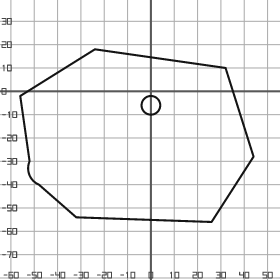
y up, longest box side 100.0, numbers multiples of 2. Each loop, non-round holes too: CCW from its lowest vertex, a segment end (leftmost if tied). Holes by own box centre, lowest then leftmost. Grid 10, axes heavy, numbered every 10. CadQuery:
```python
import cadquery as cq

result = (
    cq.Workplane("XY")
    .moveTo(26.0, -56.0)
    .lineTo(44.0, -28.0)
    .lineTo(32.0, 10.0)
    .lineTo(-24.0, 18.0)
    .lineTo(-56.0, -2.0)
    .lineTo(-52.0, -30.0)
    .threePointArc((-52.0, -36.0), (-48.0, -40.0))
    .lineTo(-32.0, -54.0)
    .close()
    .moveTo(0.0, -6.0)
    .circle(4.0)
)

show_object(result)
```